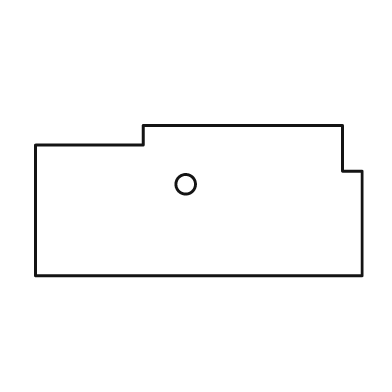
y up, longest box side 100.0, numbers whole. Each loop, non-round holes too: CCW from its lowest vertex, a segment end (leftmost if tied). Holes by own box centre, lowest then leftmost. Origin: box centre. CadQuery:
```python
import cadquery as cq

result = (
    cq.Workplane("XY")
    .moveTo(-50.0, -23.0)
    .lineTo(50.0, -23.0)
    .lineTo(50.0, 9.0)
    .lineTo(44.0, 9.0)
    .lineTo(44.0, 23.0)
    .lineTo(-17.0, 23.0)
    .lineTo(-17.0, 17.0)
    .lineTo(-50.0, 17.0)
    .close()
    .moveTo(-4.0, 5.0)
    .circle(3.0)
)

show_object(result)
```